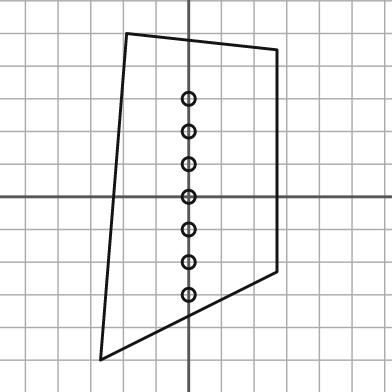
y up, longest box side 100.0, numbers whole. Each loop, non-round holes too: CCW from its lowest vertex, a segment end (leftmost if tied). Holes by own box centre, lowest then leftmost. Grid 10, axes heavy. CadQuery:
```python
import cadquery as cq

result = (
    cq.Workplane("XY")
    .moveTo(-27.0, -50.0)
    .lineTo(27.0, -23.0)
    .lineTo(27.0, 45.0)
    .lineTo(-19.0, 50.0)
    .close()
    .moveTo(0.0, -30.0)
    .circle(2.0)
    .moveTo(0.0, -20.0)
    .circle(2.0)
    .moveTo(0.0, -10.0)
    .circle(2.0)
    .moveTo(0.0, 0.0)
    .circle(2.0)
    .moveTo(0.0, 10.0)
    .circle(2.0)
    .moveTo(0.0, 20.0)
    .circle(2.0)
    .moveTo(0.0, 30.0)
    .circle(2.0)
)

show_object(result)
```